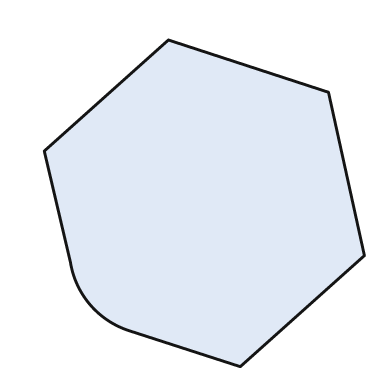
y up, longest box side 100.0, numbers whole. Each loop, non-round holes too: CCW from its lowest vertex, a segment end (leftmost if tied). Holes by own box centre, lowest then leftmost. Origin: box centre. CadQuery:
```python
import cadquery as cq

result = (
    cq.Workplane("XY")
    .moveTo(11.0, -50.0)
    .lineTo(49.0, -16.0)
    .lineTo(38.0, 34.0)
    .lineTo(-11.0, 50.0)
    .lineTo(-49.0, 16.0)
    .lineTo(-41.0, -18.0)
    .threePointArc((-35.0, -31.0), (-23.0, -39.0))
    .close()
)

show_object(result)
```